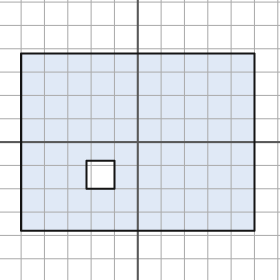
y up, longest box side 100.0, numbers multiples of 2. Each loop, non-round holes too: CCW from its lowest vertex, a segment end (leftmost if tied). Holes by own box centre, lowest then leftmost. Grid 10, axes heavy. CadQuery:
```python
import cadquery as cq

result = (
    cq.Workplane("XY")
    .moveTo(-50.0, -38.0)
    .lineTo(50.0, -38.0)
    .lineTo(50.0, 38.0)
    .lineTo(-50.0, 38.0)
    .close()
    .moveTo(-22.0, -20.0)
    .lineTo(-10.0, -20.0)
    .lineTo(-10.0, -8.0)
    .lineTo(-22.0, -8.0)
    .close()
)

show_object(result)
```